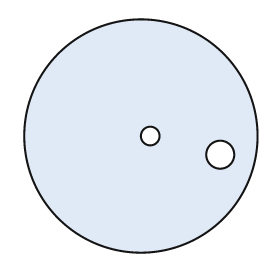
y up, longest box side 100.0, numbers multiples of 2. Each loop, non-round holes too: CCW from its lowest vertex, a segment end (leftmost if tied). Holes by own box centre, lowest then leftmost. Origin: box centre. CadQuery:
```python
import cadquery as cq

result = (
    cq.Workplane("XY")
    .moveTo(0.0, 0.0)
    .circle(50.0)
    .moveTo(34.0, -8.0)
    .circle(6.0)
    .moveTo(4.0, 0.0)
    .circle(4.0)
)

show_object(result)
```